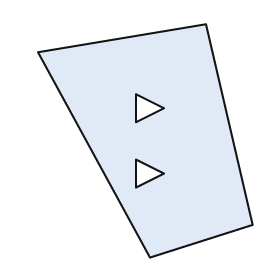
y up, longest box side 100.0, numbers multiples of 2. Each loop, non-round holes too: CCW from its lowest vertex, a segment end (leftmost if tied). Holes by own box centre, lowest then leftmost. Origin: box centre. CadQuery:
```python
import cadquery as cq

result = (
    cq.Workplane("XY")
    .moveTo(2.0, -50.0)
    .lineTo(46.0, -36.0)
    .lineTo(26.0, 50.0)
    .lineTo(-46.0, 38.0)
    .close()
    .moveTo(-4.0, -20.0)
    .lineTo(8.0, -14.0)
    .lineTo(-4.0, -8.0)
    .close()
    .moveTo(-4.0, 8.0)
    .lineTo(8.0, 14.0)
    .lineTo(-4.0, 20.0)
    .close()
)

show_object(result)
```